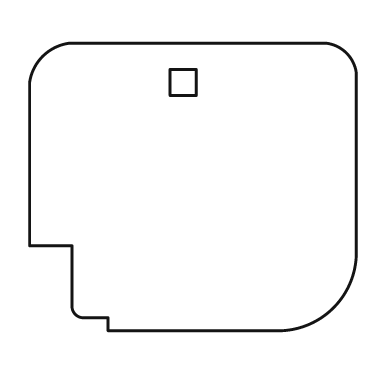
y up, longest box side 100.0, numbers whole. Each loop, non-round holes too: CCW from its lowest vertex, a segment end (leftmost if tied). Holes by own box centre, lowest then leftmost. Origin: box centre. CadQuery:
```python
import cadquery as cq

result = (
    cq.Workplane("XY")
    .moveTo(-26.0, -44.0)
    .lineTo(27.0, -44.0)
    .threePointArc((43.0, -37.0), (50.0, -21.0))
    .lineTo(50.0, 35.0)
    .threePointArc((47.0, 41.0), (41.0, 44.0))
    .lineTo(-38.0, 44.0)
    .threePointArc((-46.0, 40.0), (-50.0, 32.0))
    .lineTo(-50.0, -18.0)
    .lineTo(-37.0, -18.0)
    .lineTo(-37.0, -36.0)
    .threePointArc((-36.0, -39.0), (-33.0, -40.0))
    .lineTo(-26.0, -40.0)
    .close()
    .moveTo(-7.0, 28.0)
    .lineTo(1.0, 28.0)
    .lineTo(1.0, 36.0)
    .lineTo(-7.0, 36.0)
    .close()
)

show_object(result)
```